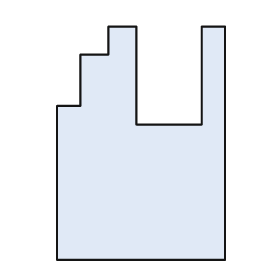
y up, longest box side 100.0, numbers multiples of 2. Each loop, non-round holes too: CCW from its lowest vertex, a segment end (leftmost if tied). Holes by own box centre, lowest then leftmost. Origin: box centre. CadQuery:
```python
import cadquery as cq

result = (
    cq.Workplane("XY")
    .moveTo(-36.0, -50.0)
    .lineTo(36.0, -50.0)
    .lineTo(36.0, 50.0)
    .lineTo(26.0, 50.0)
    .lineTo(26.0, 8.0)
    .lineTo(-2.0, 8.0)
    .lineTo(-2.0, 50.0)
    .lineTo(-14.0, 50.0)
    .lineTo(-14.0, 38.0)
    .lineTo(-26.0, 38.0)
    .lineTo(-26.0, 16.0)
    .lineTo(-36.0, 16.0)
    .close()
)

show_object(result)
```